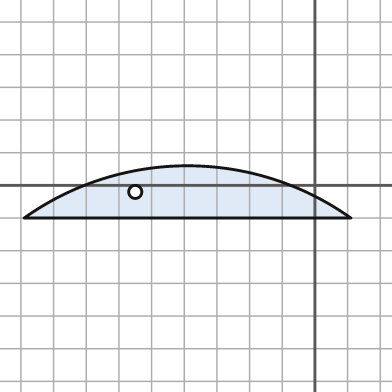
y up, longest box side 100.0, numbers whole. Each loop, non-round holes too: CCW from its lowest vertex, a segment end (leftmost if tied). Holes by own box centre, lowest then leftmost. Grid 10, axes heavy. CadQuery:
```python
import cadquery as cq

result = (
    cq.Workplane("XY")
    .moveTo(-89.0, -10.0)
    .lineTo(11.0, -10.0)
    .threePointArc((-39.0, 6.0), (-89.0, -10.0))
    .close()
    .moveTo(-55.0, -2.0)
    .circle(2.0)
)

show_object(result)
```